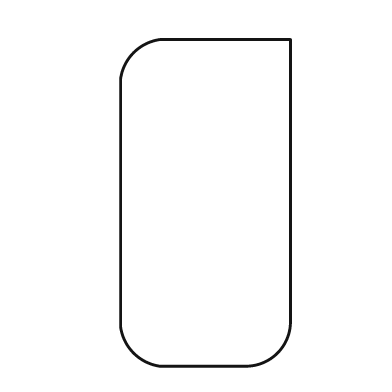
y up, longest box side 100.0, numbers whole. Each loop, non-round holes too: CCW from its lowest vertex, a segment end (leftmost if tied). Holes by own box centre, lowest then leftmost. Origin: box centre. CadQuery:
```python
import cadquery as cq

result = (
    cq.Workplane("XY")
    .moveTo(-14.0, -50.0)
    .lineTo(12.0, -50.0)
    .threePointArc((22.0, -46.0), (26.0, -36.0))
    .lineTo(26.0, 50.0)
    .lineTo(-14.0, 50.0)
    .threePointArc((-22.0, 46.0), (-26.0, 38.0))
    .lineTo(-26.0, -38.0)
    .threePointArc((-22.0, -46.0), (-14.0, -50.0))
    .close()
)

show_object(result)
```